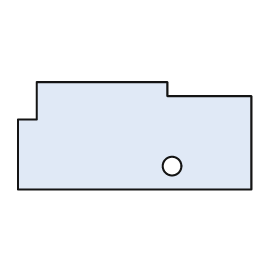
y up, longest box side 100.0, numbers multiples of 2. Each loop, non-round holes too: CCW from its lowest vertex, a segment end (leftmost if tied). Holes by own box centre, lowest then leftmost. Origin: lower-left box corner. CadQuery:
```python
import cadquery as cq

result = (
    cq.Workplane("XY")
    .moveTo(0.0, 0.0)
    .lineTo(100.0, 0.0)
    .lineTo(100.0, 40.0)
    .lineTo(64.0, 40.0)
    .lineTo(64.0, 46.0)
    .lineTo(8.0, 46.0)
    .lineTo(8.0, 30.0)
    .lineTo(0.0, 30.0)
    .close()
    .moveTo(66.0, 10.0)
    .circle(4.0)
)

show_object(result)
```